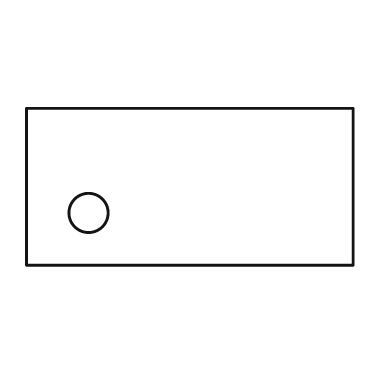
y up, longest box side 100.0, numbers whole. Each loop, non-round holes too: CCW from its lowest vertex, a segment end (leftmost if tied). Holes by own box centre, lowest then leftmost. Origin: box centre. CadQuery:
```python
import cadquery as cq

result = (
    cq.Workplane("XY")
    .moveTo(-50.0, -24.0)
    .lineTo(50.0, -24.0)
    .lineTo(50.0, 24.0)
    .lineTo(-50.0, 24.0)
    .close()
    .moveTo(-31.0, -8.0)
    .circle(6.0)
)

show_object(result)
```